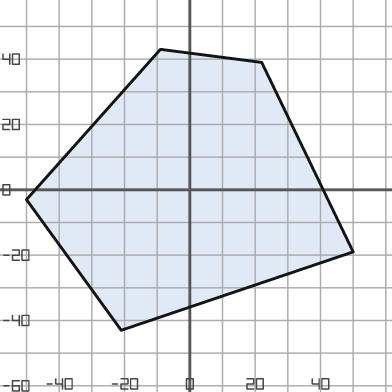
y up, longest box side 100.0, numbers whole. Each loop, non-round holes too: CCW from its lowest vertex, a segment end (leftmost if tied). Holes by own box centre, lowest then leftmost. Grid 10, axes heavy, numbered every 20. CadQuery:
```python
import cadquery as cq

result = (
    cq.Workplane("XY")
    .moveTo(-21.0, -43.0)
    .lineTo(50.0, -19.0)
    .lineTo(22.0, 39.0)
    .lineTo(-9.0, 43.0)
    .lineTo(-50.0, -3.0)
    .close()
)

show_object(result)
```